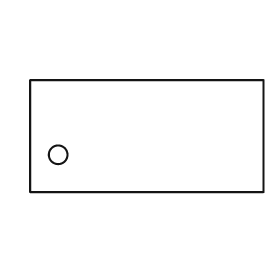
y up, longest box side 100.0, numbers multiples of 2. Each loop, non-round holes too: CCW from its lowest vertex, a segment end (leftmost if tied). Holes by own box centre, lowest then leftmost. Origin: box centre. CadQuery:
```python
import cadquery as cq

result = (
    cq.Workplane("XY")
    .moveTo(-50.0, -24.0)
    .lineTo(50.0, -24.0)
    .lineTo(50.0, 24.0)
    .lineTo(-50.0, 24.0)
    .close()
    .moveTo(-38.0, -8.0)
    .circle(4.0)
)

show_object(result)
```